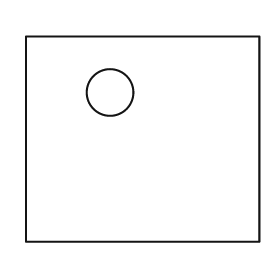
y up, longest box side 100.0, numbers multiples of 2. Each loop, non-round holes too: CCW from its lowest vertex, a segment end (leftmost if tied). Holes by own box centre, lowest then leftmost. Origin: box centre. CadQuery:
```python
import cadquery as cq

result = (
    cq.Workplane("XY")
    .moveTo(-50.0, -44.0)
    .lineTo(50.0, -44.0)
    .lineTo(50.0, 44.0)
    .lineTo(-50.0, 44.0)
    .close()
    .moveTo(-14.0, 20.0)
    .circle(10.0)
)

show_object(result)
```